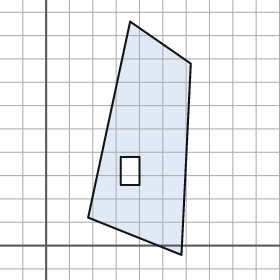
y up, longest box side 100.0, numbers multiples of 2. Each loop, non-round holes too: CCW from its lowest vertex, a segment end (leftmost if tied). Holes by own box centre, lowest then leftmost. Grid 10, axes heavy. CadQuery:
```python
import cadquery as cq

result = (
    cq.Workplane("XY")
    .moveTo(58.0, -4.0)
    .lineTo(62.0, 78.0)
    .lineTo(36.0, 96.0)
    .lineTo(18.0, 12.0)
    .close()
    .moveTo(32.0, 26.0)
    .lineTo(40.0, 26.0)
    .lineTo(40.0, 38.0)
    .lineTo(32.0, 38.0)
    .close()
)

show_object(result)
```